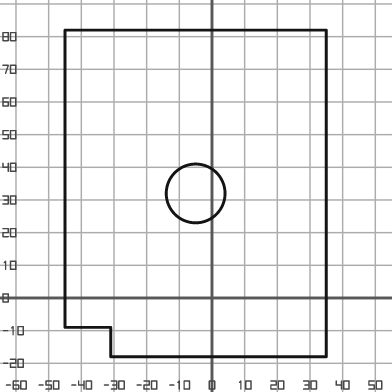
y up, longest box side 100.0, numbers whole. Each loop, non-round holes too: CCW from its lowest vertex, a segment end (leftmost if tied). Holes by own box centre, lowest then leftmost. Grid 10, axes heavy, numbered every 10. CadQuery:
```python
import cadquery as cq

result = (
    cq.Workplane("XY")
    .moveTo(-31.0, -18.0)
    .lineTo(35.0, -18.0)
    .lineTo(35.0, 82.0)
    .lineTo(-45.0, 82.0)
    .lineTo(-45.0, -9.0)
    .lineTo(-31.0, -9.0)
    .close()
    .moveTo(-5.0, 32.0)
    .circle(9.0)
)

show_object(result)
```